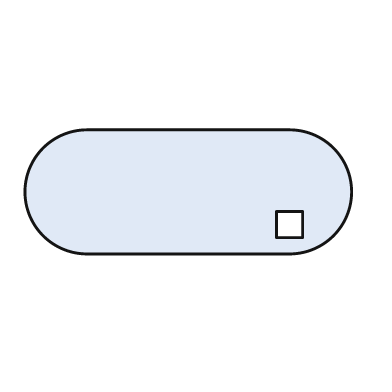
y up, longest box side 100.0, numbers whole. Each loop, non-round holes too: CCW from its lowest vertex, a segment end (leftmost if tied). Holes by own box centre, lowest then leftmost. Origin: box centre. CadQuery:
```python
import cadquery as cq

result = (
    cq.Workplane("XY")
    .moveTo(-31.0, -19.0)
    .lineTo(31.0, -19.0)
    .threePointArc((50.0, 0.0), (31.0, 19.0))
    .lineTo(-31.0, 19.0)
    .threePointArc((-50.0, 0.0), (-31.0, -19.0))
    .close()
    .moveTo(27.0, -14.0)
    .lineTo(35.0, -14.0)
    .lineTo(35.0, -6.0)
    .lineTo(27.0, -6.0)
    .close()
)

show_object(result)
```